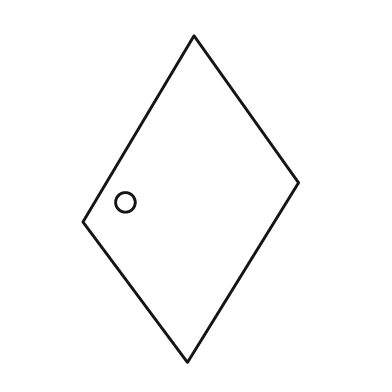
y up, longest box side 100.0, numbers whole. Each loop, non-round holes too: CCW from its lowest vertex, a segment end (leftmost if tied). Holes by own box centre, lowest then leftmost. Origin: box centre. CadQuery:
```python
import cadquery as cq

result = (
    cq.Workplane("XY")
    .moveTo(-1.0, -50.0)
    .lineTo(33.0, 5.0)
    .lineTo(1.0, 50.0)
    .lineTo(-33.0, -7.0)
    .close()
    .moveTo(-20.0, -1.0)
    .circle(3.0)
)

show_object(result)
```